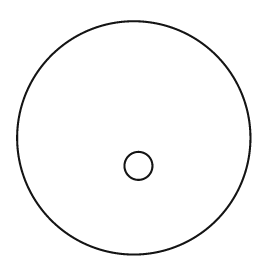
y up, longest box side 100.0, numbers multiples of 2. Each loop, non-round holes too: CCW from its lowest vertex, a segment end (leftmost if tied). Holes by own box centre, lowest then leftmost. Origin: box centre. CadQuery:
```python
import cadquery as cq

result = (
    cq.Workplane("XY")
    .moveTo(0.0, 0.0)
    .circle(50.0)
    .moveTo(2.0, -12.0)
    .circle(6.0)
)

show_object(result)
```